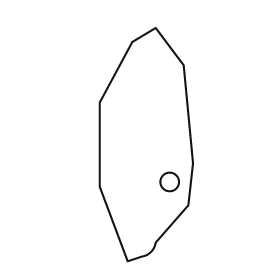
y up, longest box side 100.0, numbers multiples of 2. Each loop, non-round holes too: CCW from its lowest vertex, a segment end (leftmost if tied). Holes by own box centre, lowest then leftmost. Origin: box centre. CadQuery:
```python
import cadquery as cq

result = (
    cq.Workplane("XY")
    .moveTo(-8.0, -50.0)
    .lineTo(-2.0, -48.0)
    .threePointArc((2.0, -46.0), (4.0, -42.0))
    .lineTo(18.0, -26.0)
    .lineTo(20.0, -8.0)
    .lineTo(16.0, 34.0)
    .lineTo(4.0, 50.0)
    .lineTo(-6.0, 44.0)
    .lineTo(-20.0, 18.0)
    .lineTo(-20.0, -18.0)
    .close()
    .moveTo(10.0, -16.0)
    .circle(4.0)
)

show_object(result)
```